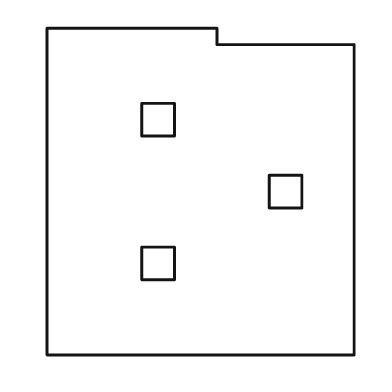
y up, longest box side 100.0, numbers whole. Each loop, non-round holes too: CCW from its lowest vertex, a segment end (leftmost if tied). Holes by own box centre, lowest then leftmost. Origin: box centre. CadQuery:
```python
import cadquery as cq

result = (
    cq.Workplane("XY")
    .moveTo(-47.0, -50.0)
    .lineTo(47.0, -50.0)
    .lineTo(47.0, 45.0)
    .lineTo(5.0, 45.0)
    .lineTo(5.0, 50.0)
    .lineTo(-47.0, 50.0)
    .close()
    .moveTo(-18.0, -27.0)
    .lineTo(-8.0, -27.0)
    .lineTo(-8.0, -17.0)
    .lineTo(-18.0, -17.0)
    .close()
    .moveTo(21.0, -5.0)
    .lineTo(31.0, -5.0)
    .lineTo(31.0, 5.0)
    .lineTo(21.0, 5.0)
    .close()
    .moveTo(-18.0, 17.0)
    .lineTo(-8.0, 17.0)
    .lineTo(-8.0, 27.0)
    .lineTo(-18.0, 27.0)
    .close()
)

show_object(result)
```